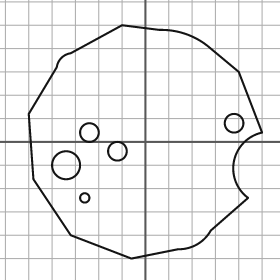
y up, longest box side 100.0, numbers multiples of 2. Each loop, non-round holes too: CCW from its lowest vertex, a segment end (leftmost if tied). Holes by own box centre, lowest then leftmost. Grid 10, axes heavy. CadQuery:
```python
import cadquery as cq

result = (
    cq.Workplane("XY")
    .moveTo(-6.0, -50.0)
    .lineTo(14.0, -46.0)
    .threePointArc((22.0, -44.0), (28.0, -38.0))
    .lineTo(44.0, -24.0)
    .threePointArc((38.0, -8.0), (50.0, 4.0))
    .lineTo(40.0, 30.0)
    .lineTo(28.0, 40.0)
    .threePointArc((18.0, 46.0), (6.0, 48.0))
    .lineTo(-10.0, 50.0)
    .lineTo(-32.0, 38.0)
    .threePointArc((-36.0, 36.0), (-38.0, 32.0))
    .lineTo(-50.0, 12.0)
    .lineTo(-48.0, -16.0)
    .lineTo(-32.0, -40.0)
    .close()
    .moveTo(-26.0, -24.0)
    .circle(2.0)
    .moveTo(-34.0, -10.0)
    .circle(6.0)
    .moveTo(-12.0, -4.0)
    .circle(4.0)
    .moveTo(-24.0, 4.0)
    .circle(4.0)
    .moveTo(38.0, 8.0)
    .circle(4.0)
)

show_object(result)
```